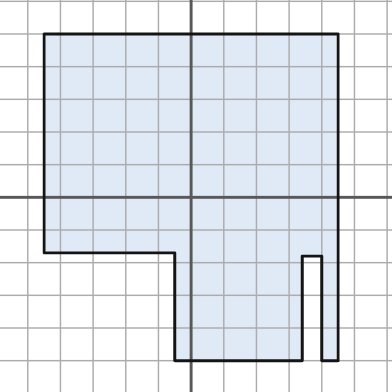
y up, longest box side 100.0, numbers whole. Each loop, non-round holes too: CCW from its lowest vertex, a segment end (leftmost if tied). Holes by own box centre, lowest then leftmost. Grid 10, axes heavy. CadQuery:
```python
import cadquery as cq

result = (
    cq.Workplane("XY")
    .moveTo(-5.0, -50.0)
    .lineTo(34.0, -50.0)
    .lineTo(34.0, -18.0)
    .lineTo(40.0, -18.0)
    .lineTo(40.0, -50.0)
    .lineTo(45.0, -50.0)
    .lineTo(45.0, 50.0)
    .lineTo(-45.0, 50.0)
    .lineTo(-45.0, -17.0)
    .lineTo(-5.0, -17.0)
    .close()
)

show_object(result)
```